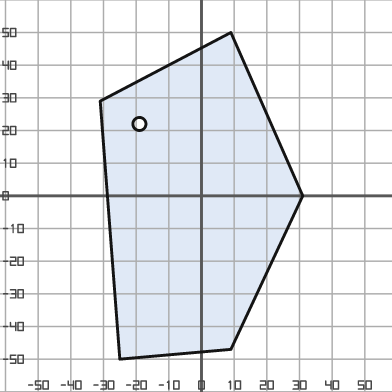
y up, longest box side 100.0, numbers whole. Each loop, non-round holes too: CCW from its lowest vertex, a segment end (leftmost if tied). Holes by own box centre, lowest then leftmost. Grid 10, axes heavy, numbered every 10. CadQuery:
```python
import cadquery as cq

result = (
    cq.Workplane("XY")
    .moveTo(-25.0, -50.0)
    .lineTo(9.0, -47.0)
    .lineTo(31.0, 0.0)
    .lineTo(9.0, 50.0)
    .lineTo(-31.0, 29.0)
    .close()
    .moveTo(-19.0, 22.0)
    .circle(2.0)
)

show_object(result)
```